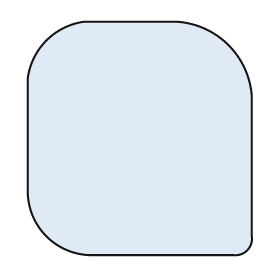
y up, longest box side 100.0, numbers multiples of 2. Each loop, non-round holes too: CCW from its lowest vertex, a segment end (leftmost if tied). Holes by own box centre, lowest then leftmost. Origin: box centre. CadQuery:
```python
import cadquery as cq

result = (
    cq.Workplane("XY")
    .moveTo(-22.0, -50.0)
    .lineTo(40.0, -50.0)
    .threePointArc((46.0, -48.0), (48.0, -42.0))
    .lineTo(48.0, 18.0)
    .threePointArc((38.0, 40.0), (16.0, 50.0))
    .lineTo(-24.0, 50.0)
    .threePointArc((-40.0, 42.0), (-48.0, 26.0))
    .lineTo(-48.0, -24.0)
    .threePointArc((-40.0, -42.0), (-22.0, -50.0))
    .close()
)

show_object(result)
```